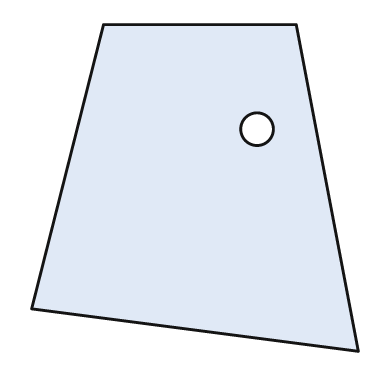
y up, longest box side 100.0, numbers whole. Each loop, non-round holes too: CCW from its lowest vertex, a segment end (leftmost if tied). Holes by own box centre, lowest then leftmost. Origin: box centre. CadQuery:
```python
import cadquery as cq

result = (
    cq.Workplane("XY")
    .moveTo(50.0, -50.0)
    .lineTo(31.0, 50.0)
    .lineTo(-28.0, 50.0)
    .lineTo(-50.0, -37.0)
    .close()
    .moveTo(19.0, 18.0)
    .circle(5.0)
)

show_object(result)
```